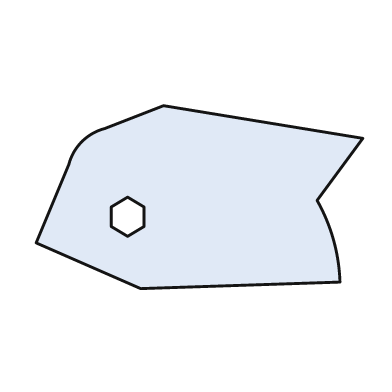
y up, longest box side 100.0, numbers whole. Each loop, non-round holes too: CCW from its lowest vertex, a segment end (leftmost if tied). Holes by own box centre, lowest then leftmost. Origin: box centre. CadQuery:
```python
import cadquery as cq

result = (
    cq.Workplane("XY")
    .moveTo(-18.0, -28.0)
    .lineTo(43.0, -26.0)
    .threePointArc((41.0, -13.0), (36.0, -1.0))
    .lineTo(50.0, 18.0)
    .lineTo(-11.0, 28.0)
    .lineTo(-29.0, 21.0)
    .threePointArc((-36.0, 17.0), (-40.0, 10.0))
    .lineTo(-50.0, -14.0)
    .close()
    .moveTo(-22.0, -12.0)
    .lineTo(-17.0, -9.0)
    .lineTo(-17.0, -3.0)
    .lineTo(-22.0, 0.0)
    .lineTo(-27.0, -3.0)
    .lineTo(-27.0, -9.0)
    .close()
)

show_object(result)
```